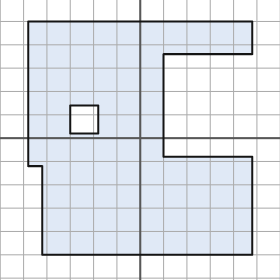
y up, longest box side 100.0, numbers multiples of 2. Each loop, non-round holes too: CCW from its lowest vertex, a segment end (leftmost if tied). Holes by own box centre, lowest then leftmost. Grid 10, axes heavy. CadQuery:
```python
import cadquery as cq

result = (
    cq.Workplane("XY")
    .moveTo(-42.0, -50.0)
    .lineTo(48.0, -50.0)
    .lineTo(48.0, -8.0)
    .lineTo(10.0, -8.0)
    .lineTo(10.0, 36.0)
    .lineTo(48.0, 36.0)
    .lineTo(48.0, 50.0)
    .lineTo(-48.0, 50.0)
    .lineTo(-48.0, -12.0)
    .lineTo(-42.0, -12.0)
    .close()
    .moveTo(-30.0, 2.0)
    .lineTo(-18.0, 2.0)
    .lineTo(-18.0, 14.0)
    .lineTo(-30.0, 14.0)
    .close()
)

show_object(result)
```